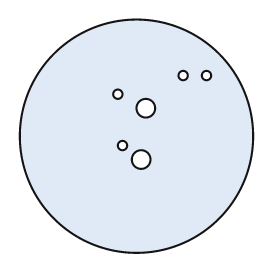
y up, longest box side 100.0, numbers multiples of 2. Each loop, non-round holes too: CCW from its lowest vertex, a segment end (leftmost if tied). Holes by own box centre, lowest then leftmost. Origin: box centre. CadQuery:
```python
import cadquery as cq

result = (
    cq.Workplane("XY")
    .moveTo(0.0, 0.0)
    .circle(50.0)
    .moveTo(2.0, -10.0)
    .circle(4.0)
    .moveTo(-6.0, -4.0)
    .circle(2.0)
    .moveTo(4.0, 12.0)
    .circle(4.0)
    .moveTo(-8.0, 18.0)
    .circle(2.0)
    .moveTo(20.0, 26.0)
    .circle(2.0)
    .moveTo(30.0, 26.0)
    .circle(2.0)
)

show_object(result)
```